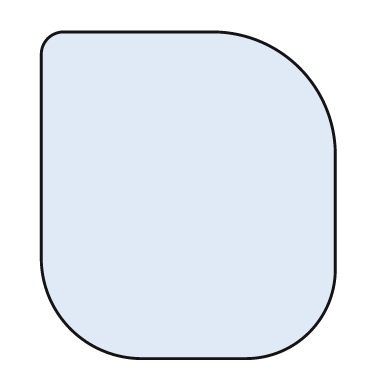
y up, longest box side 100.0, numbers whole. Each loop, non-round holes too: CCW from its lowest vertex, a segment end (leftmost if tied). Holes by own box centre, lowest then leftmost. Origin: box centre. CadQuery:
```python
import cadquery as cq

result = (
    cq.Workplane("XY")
    .moveTo(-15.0, -50.0)
    .lineTo(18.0, -50.0)
    .threePointArc((37.0, -42.0), (45.0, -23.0))
    .lineTo(45.0, 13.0)
    .threePointArc((34.0, 39.0), (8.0, 50.0))
    .lineTo(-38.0, 50.0)
    .threePointArc((-43.0, 48.0), (-45.0, 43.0))
    .lineTo(-45.0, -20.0)
    .threePointArc((-36.0, -41.0), (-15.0, -50.0))
    .close()
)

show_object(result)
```